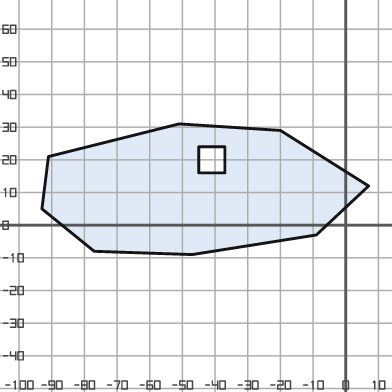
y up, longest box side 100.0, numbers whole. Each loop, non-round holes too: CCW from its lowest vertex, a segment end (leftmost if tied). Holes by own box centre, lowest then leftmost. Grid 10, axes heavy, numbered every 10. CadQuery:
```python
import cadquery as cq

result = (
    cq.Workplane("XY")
    .moveTo(-47.0, -9.0)
    .lineTo(-9.0, -3.0)
    .lineTo(7.0, 12.0)
    .lineTo(-20.0, 29.0)
    .lineTo(-51.0, 31.0)
    .lineTo(-91.0, 21.0)
    .lineTo(-93.0, 5.0)
    .lineTo(-77.0, -8.0)
    .close()
    .moveTo(-45.0, 16.0)
    .lineTo(-37.0, 16.0)
    .lineTo(-37.0, 24.0)
    .lineTo(-45.0, 24.0)
    .close()
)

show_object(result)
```